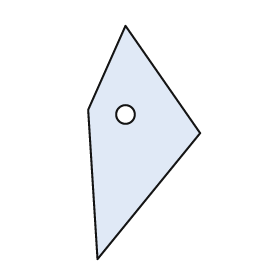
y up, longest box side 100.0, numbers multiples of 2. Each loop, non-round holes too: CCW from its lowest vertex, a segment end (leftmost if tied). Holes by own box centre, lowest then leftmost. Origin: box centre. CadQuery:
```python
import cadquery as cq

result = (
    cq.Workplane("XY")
    .moveTo(-20.0, -50.0)
    .lineTo(24.0, 4.0)
    .lineTo(-8.0, 50.0)
    .lineTo(-24.0, 14.0)
    .close()
    .moveTo(-8.0, 12.0)
    .circle(4.0)
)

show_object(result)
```